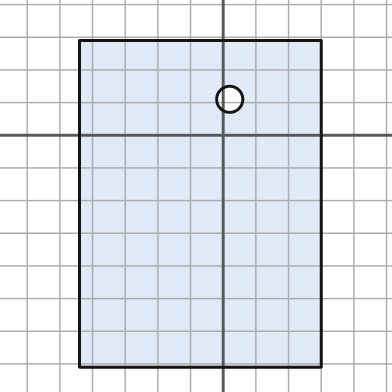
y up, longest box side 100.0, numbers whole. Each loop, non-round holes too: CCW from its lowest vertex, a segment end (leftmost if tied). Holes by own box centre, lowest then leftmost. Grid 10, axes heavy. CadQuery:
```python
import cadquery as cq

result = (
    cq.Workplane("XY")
    .moveTo(-44.0, -71.0)
    .lineTo(30.0, -71.0)
    .lineTo(30.0, 29.0)
    .lineTo(-44.0, 29.0)
    .close()
    .moveTo(2.0, 11.0)
    .circle(4.0)
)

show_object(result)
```